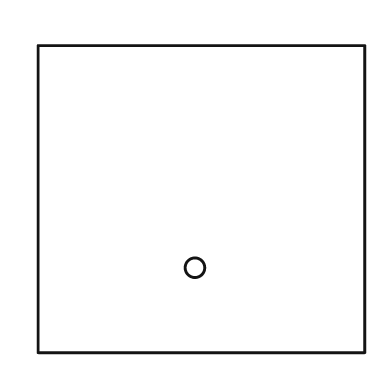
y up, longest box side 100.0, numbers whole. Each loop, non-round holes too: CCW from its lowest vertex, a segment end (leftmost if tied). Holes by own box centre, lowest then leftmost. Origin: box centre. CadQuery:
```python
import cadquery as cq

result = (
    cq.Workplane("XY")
    .moveTo(-50.0, -47.0)
    .lineTo(50.0, -47.0)
    .lineTo(50.0, 47.0)
    .lineTo(-50.0, 47.0)
    .close()
    .moveTo(-2.0, -21.0)
    .circle(3.0)
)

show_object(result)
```